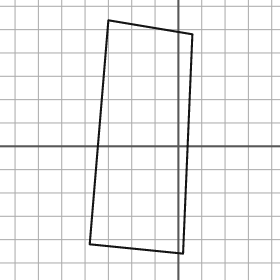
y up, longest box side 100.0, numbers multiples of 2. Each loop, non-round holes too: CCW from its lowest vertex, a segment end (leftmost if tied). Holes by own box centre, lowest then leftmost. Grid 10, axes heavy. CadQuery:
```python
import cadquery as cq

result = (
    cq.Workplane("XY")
    .moveTo(2.0, -46.0)
    .lineTo(6.0, 48.0)
    .lineTo(-30.0, 54.0)
    .lineTo(-38.0, -42.0)
    .close()
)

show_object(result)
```